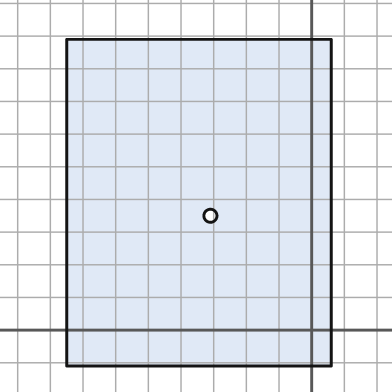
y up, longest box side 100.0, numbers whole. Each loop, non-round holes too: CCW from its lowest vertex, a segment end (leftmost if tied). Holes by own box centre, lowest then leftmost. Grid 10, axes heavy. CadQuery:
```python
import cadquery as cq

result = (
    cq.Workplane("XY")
    .moveTo(-75.0, -11.0)
    .lineTo(6.0, -11.0)
    .lineTo(6.0, 89.0)
    .lineTo(-75.0, 89.0)
    .close()
    .moveTo(-31.0, 35.0)
    .circle(2.0)
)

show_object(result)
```